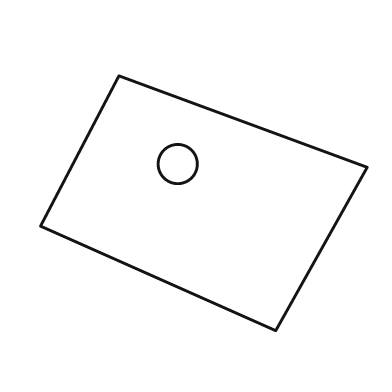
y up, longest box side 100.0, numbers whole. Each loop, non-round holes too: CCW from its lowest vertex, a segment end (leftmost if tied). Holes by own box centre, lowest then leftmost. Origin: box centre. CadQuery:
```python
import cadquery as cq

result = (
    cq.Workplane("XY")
    .moveTo(22.0, -39.0)
    .lineTo(50.0, 11.0)
    .lineTo(-26.0, 39.0)
    .lineTo(-50.0, -7.0)
    .close()
    .moveTo(-8.0, 12.0)
    .circle(6.0)
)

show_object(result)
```